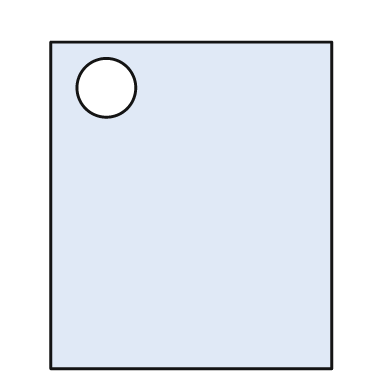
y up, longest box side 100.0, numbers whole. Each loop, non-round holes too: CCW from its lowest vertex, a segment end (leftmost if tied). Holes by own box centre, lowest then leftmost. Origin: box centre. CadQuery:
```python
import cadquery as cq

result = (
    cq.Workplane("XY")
    .moveTo(-43.0, -50.0)
    .lineTo(43.0, -50.0)
    .lineTo(43.0, 50.0)
    .lineTo(-43.0, 50.0)
    .close()
    .moveTo(-26.0, 36.0)
    .circle(9.0)
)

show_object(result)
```